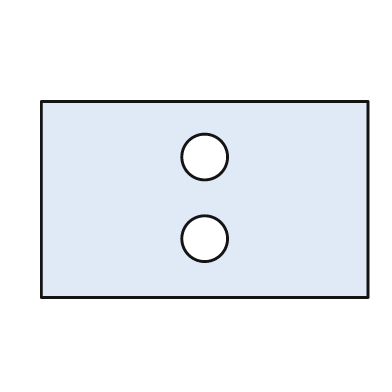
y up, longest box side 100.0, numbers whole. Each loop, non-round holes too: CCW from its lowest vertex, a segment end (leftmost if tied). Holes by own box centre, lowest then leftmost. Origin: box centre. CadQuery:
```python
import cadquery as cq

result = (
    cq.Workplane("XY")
    .moveTo(-50.0, -30.0)
    .lineTo(50.0, -30.0)
    .lineTo(50.0, 30.0)
    .lineTo(-50.0, 30.0)
    .close()
    .moveTo(0.0, -12.0)
    .circle(7.0)
    .moveTo(0.0, 13.0)
    .circle(7.0)
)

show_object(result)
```